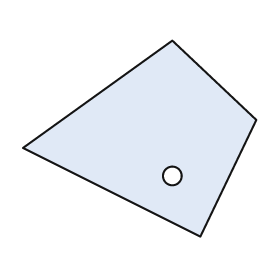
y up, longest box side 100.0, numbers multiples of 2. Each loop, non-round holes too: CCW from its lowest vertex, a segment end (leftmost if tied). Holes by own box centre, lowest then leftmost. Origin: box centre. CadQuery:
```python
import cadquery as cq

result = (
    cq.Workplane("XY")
    .moveTo(26.0, -42.0)
    .lineTo(50.0, 8.0)
    .lineTo(14.0, 42.0)
    .lineTo(-50.0, -4.0)
    .close()
    .moveTo(14.0, -16.0)
    .circle(4.0)
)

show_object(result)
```